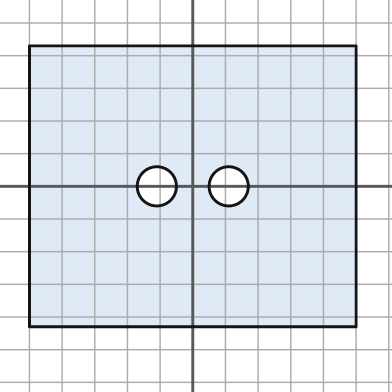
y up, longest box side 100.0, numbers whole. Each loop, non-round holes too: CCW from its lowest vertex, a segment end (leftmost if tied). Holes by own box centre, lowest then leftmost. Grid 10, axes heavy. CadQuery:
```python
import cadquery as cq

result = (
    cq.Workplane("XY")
    .moveTo(-50.0, -43.0)
    .lineTo(50.0, -43.0)
    .lineTo(50.0, 43.0)
    .lineTo(-50.0, 43.0)
    .close()
    .moveTo(-11.0, 0.0)
    .circle(6.0)
    .moveTo(11.0, 0.0)
    .circle(6.0)
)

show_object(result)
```